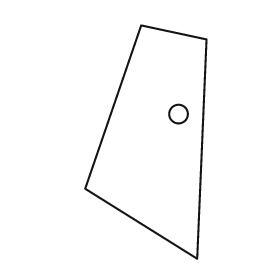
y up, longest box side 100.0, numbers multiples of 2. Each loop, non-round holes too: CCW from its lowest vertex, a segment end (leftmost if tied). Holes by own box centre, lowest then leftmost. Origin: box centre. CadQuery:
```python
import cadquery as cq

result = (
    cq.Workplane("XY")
    .moveTo(22.0, -50.0)
    .lineTo(26.0, 44.0)
    .lineTo(-2.0, 50.0)
    .lineTo(-26.0, -20.0)
    .close()
    .moveTo(14.0, 12.0)
    .circle(4.0)
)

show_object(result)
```